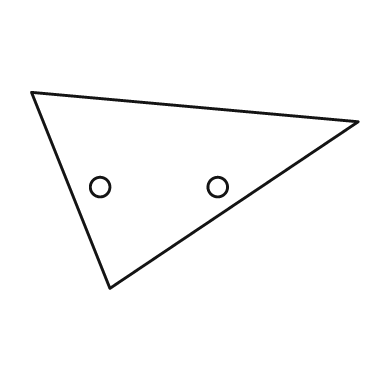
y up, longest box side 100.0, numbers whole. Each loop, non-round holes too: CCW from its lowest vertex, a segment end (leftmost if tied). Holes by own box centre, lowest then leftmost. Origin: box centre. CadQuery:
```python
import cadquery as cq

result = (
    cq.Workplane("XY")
    .moveTo(-26.0, -30.0)
    .lineTo(50.0, 21.0)
    .lineTo(-50.0, 30.0)
    .close()
    .moveTo(-29.0, 1.0)
    .circle(3.0)
    .moveTo(7.0, 1.0)
    .circle(3.0)
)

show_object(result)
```